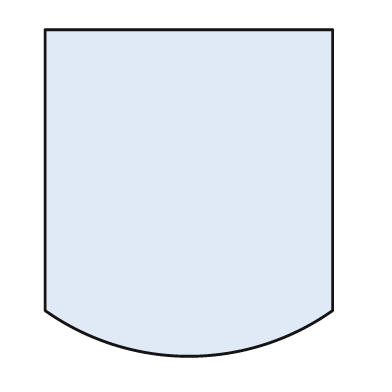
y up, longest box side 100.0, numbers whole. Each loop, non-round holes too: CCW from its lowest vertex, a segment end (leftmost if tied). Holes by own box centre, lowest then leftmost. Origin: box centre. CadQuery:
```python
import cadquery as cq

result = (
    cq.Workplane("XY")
    .moveTo(-44.0, -36.0)
    .threePointArc((0.0, -50.0), (44.0, -36.0))
    .lineTo(44.0, 50.0)
    .lineTo(-44.0, 50.0)
    .close()
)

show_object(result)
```